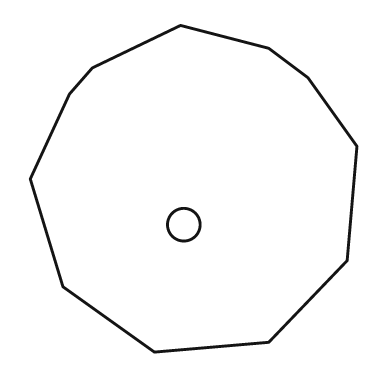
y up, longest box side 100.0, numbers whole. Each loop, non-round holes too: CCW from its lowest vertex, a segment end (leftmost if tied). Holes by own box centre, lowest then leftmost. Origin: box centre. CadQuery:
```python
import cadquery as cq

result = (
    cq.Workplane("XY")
    .moveTo(-12.0, -50.0)
    .lineTo(23.0, -47.0)
    .lineTo(47.0, -22.0)
    .lineTo(50.0, 13.0)
    .lineTo(35.0, 34.0)
    .lineTo(23.0, 43.0)
    .lineTo(-4.0, 50.0)
    .lineTo(-31.0, 37.0)
    .lineTo(-38.0, 29.0)
    .lineTo(-50.0, 3.0)
    .lineTo(-40.0, -30.0)
    .close()
    .moveTo(-3.0, -11.0)
    .circle(5.0)
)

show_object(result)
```